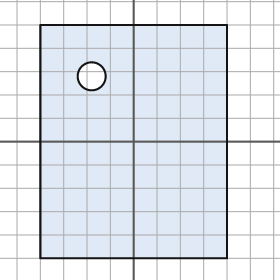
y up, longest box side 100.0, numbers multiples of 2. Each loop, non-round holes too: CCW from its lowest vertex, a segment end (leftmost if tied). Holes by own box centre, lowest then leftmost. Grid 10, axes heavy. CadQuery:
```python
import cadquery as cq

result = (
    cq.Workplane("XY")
    .moveTo(-40.0, -50.0)
    .lineTo(40.0, -50.0)
    .lineTo(40.0, 50.0)
    .lineTo(-40.0, 50.0)
    .close()
    .moveTo(-18.0, 28.0)
    .circle(6.0)
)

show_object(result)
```